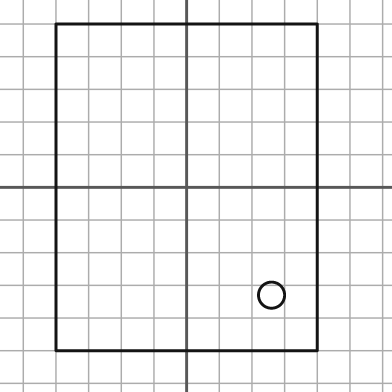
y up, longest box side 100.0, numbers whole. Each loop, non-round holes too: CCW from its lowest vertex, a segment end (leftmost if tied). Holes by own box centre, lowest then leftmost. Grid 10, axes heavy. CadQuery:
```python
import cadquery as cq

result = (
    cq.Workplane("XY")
    .moveTo(-40.0, -50.0)
    .lineTo(40.0, -50.0)
    .lineTo(40.0, 50.0)
    .lineTo(-40.0, 50.0)
    .close()
    .moveTo(26.0, -33.0)
    .circle(4.0)
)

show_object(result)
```